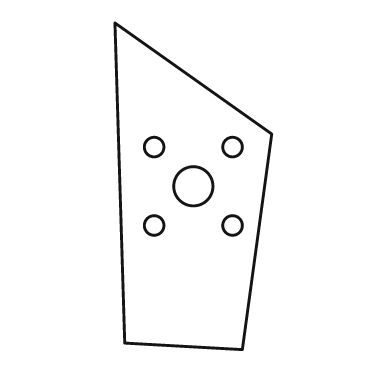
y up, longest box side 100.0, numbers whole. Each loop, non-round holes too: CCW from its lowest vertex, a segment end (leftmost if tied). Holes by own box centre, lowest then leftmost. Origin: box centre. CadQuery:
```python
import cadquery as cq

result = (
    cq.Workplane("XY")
    .moveTo(15.0, -50.0)
    .lineTo(24.0, 16.0)
    .lineTo(-24.0, 50.0)
    .lineTo(-21.0, -48.0)
    .close()
    .moveTo(-12.0, -12.0)
    .circle(3.0)
    .moveTo(12.0, -12.0)
    .circle(3.0)
    .moveTo(0.0, 0.0)
    .circle(6.0)
    .moveTo(-12.0, 12.0)
    .circle(3.0)
    .moveTo(12.0, 12.0)
    .circle(3.0)
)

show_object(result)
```